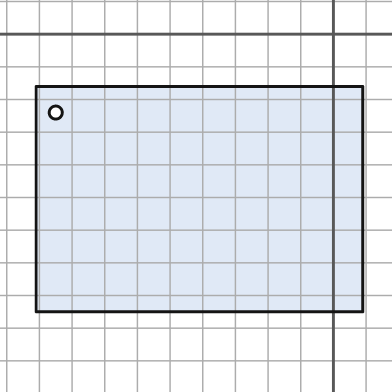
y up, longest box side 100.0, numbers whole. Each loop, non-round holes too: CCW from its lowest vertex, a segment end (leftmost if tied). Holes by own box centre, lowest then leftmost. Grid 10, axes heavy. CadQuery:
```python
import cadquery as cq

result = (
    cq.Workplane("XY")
    .moveTo(-91.0, -85.0)
    .lineTo(9.0, -85.0)
    .lineTo(9.0, -16.0)
    .lineTo(-91.0, -16.0)
    .close()
    .moveTo(-85.0, -24.0)
    .circle(2.0)
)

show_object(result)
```